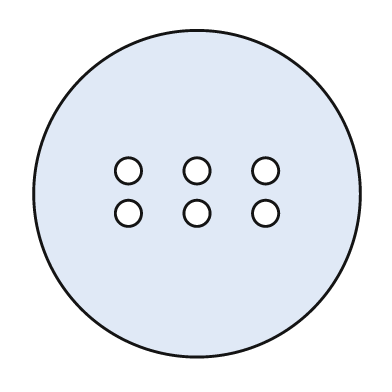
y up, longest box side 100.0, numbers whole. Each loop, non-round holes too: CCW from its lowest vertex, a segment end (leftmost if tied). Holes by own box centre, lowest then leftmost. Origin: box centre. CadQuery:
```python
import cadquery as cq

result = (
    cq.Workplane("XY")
    .moveTo(0.0, 0.0)
    .circle(50.0)
    .moveTo(-21.0, -6.0)
    .circle(4.0)
    .moveTo(0.0, -6.0)
    .circle(4.0)
    .moveTo(21.0, -6.0)
    .circle(4.0)
    .moveTo(-21.0, 7.0)
    .circle(4.0)
    .moveTo(0.0, 7.0)
    .circle(4.0)
    .moveTo(21.0, 7.0)
    .circle(4.0)
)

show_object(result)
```